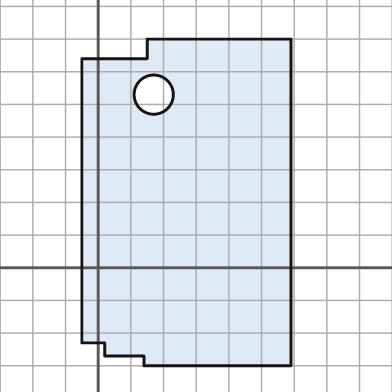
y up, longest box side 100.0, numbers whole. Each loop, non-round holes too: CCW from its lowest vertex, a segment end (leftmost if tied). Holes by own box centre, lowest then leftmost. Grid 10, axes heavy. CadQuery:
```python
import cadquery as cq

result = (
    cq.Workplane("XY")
    .moveTo(14.0, -30.0)
    .lineTo(59.0, -30.0)
    .lineTo(59.0, 70.0)
    .lineTo(15.0, 70.0)
    .lineTo(15.0, 64.0)
    .lineTo(-5.0, 64.0)
    .lineTo(-5.0, -23.0)
    .lineTo(2.0, -23.0)
    .lineTo(2.0, -27.0)
    .lineTo(14.0, -27.0)
    .close()
    .moveTo(17.0, 53.0)
    .circle(6.0)
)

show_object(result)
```